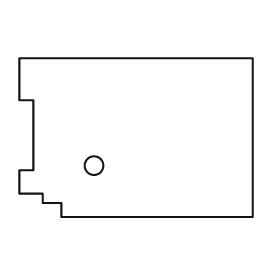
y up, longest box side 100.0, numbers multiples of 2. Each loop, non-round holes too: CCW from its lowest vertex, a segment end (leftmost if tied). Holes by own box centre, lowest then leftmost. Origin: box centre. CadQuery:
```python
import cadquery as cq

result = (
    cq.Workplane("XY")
    .moveTo(-32.0, -34.0)
    .lineTo(50.0, -34.0)
    .lineTo(50.0, 34.0)
    .lineTo(-50.0, 34.0)
    .lineTo(-50.0, 16.0)
    .lineTo(-44.0, 16.0)
    .lineTo(-44.0, -14.0)
    .lineTo(-50.0, -14.0)
    .lineTo(-50.0, -24.0)
    .lineTo(-40.0, -24.0)
    .lineTo(-40.0, -28.0)
    .lineTo(-32.0, -28.0)
    .close()
    .moveTo(-18.0, -12.0)
    .circle(4.0)
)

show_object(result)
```